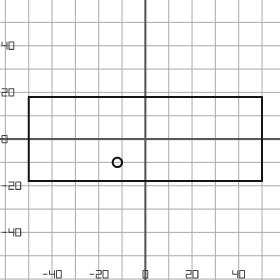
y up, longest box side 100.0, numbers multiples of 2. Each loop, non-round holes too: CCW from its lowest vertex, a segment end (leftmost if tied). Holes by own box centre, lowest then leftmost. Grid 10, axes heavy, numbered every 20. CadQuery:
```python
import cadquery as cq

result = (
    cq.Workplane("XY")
    .moveTo(-50.0, -18.0)
    .lineTo(50.0, -18.0)
    .lineTo(50.0, 18.0)
    .lineTo(-50.0, 18.0)
    .close()
    .moveTo(-12.0, -10.0)
    .circle(2.0)
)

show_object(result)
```